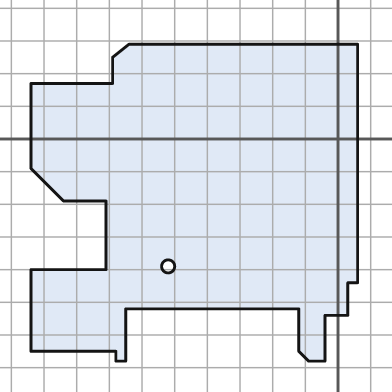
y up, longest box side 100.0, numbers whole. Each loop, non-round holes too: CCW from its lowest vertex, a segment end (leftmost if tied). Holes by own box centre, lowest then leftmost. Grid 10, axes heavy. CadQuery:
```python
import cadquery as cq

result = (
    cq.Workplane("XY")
    .moveTo(-68.0, -68.0)
    .lineTo(-65.0, -68.0)
    .lineTo(-65.0, -52.0)
    .lineTo(-12.0, -52.0)
    .lineTo(-12.0, -65.0)
    .lineTo(-9.0, -68.0)
    .lineTo(-4.0, -68.0)
    .lineTo(-4.0, -54.0)
    .lineTo(3.0, -54.0)
    .lineTo(3.0, -44.0)
    .lineTo(6.0, -44.0)
    .lineTo(6.0, 29.0)
    .lineTo(-64.0, 29.0)
    .lineTo(-69.0, 25.0)
    .lineTo(-69.0, 17.0)
    .lineTo(-94.0, 17.0)
    .lineTo(-94.0, -9.0)
    .lineTo(-84.0, -19.0)
    .lineTo(-71.0, -19.0)
    .lineTo(-71.0, -40.0)
    .lineTo(-94.0, -40.0)
    .lineTo(-94.0, -65.0)
    .lineTo(-68.0, -65.0)
    .close()
    .moveTo(-52.0, -39.0)
    .circle(2.0)
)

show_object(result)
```